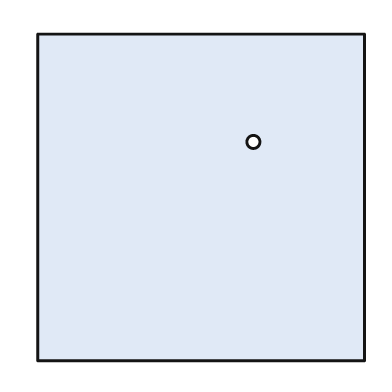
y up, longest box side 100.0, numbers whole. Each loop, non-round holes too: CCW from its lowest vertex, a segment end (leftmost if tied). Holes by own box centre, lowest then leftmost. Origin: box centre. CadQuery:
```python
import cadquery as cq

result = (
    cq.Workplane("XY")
    .moveTo(-50.0, -50.0)
    .lineTo(50.0, -50.0)
    .lineTo(50.0, 50.0)
    .lineTo(-50.0, 50.0)
    .close()
    .moveTo(16.0, 17.0)
    .circle(2.0)
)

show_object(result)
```